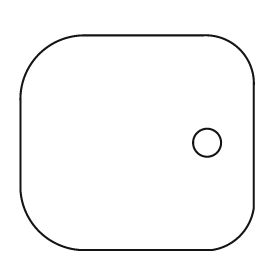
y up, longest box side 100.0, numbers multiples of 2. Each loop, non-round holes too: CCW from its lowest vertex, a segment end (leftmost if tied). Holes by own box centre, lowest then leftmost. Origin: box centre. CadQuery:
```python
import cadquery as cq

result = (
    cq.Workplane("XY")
    .moveTo(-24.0, -46.0)
    .lineTo(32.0, -46.0)
    .threePointArc((44.0, -40.0), (50.0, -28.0))
    .lineTo(50.0, 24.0)
    .threePointArc((44.0, 40.0), (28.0, 46.0))
    .lineTo(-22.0, 46.0)
    .threePointArc((-42.0, 38.0), (-50.0, 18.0))
    .lineTo(-50.0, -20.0)
    .threePointArc((-42.0, -38.0), (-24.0, -46.0))
    .close()
    .moveTo(30.0, 0.0)
    .circle(6.0)
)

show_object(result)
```